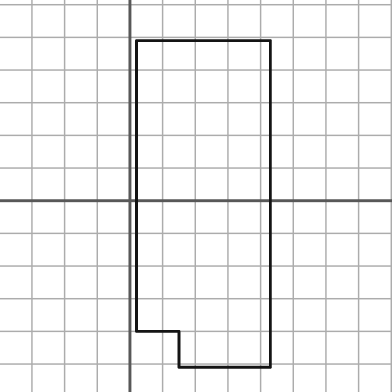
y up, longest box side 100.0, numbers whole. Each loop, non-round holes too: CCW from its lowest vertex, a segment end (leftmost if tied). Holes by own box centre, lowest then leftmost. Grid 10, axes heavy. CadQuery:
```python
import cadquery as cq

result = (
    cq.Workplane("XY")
    .moveTo(15.0, -51.0)
    .lineTo(43.0, -51.0)
    .lineTo(43.0, 49.0)
    .lineTo(2.0, 49.0)
    .lineTo(2.0, -40.0)
    .lineTo(15.0, -40.0)
    .close()
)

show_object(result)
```